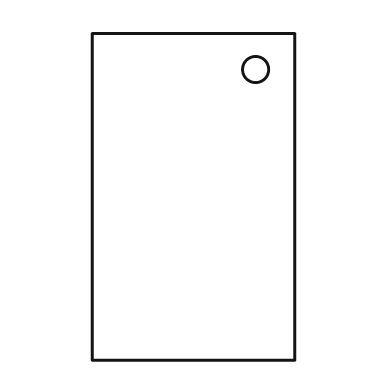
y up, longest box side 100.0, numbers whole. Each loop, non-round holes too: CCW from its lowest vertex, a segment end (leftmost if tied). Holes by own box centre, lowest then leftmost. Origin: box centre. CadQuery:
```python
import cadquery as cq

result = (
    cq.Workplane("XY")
    .moveTo(-31.0, -50.0)
    .lineTo(31.0, -50.0)
    .lineTo(31.0, 50.0)
    .lineTo(-31.0, 50.0)
    .close()
    .moveTo(19.0, 39.0)
    .circle(4.0)
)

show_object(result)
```